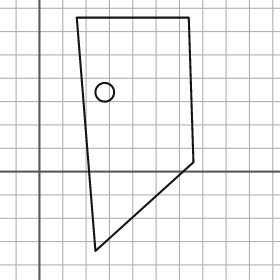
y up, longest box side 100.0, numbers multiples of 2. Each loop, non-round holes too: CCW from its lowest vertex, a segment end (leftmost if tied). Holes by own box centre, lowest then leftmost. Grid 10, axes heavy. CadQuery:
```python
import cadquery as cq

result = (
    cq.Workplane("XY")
    .moveTo(24.0, -34.0)
    .lineTo(66.0, 4.0)
    .lineTo(64.0, 66.0)
    .lineTo(16.0, 66.0)
    .close()
    .moveTo(28.0, 34.0)
    .circle(4.0)
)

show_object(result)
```